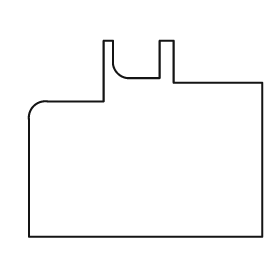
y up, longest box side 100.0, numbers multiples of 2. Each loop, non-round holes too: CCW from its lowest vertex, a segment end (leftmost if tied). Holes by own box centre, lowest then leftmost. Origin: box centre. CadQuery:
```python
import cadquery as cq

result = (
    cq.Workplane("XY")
    .moveTo(-50.0, -42.0)
    .lineTo(50.0, -42.0)
    .lineTo(50.0, 24.0)
    .lineTo(12.0, 24.0)
    .lineTo(12.0, 42.0)
    .lineTo(6.0, 42.0)
    .lineTo(6.0, 26.0)
    .lineTo(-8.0, 26.0)
    .threePointArc((-12.0, 28.0), (-14.0, 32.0))
    .lineTo(-14.0, 42.0)
    .lineTo(-18.0, 42.0)
    .lineTo(-18.0, 16.0)
    .lineTo(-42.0, 16.0)
    .threePointArc((-48.0, 14.0), (-50.0, 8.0))
    .close()
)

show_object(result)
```